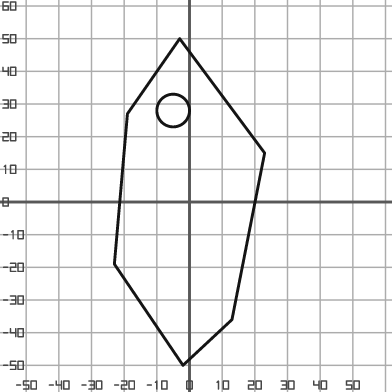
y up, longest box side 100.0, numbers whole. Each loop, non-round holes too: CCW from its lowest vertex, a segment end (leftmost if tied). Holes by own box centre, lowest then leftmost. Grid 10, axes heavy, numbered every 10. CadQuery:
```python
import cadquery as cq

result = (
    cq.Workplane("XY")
    .moveTo(-2.0, -50.0)
    .lineTo(13.0, -36.0)
    .lineTo(23.0, 15.0)
    .lineTo(-3.0, 50.0)
    .lineTo(-19.0, 27.0)
    .lineTo(-23.0, -19.0)
    .close()
    .moveTo(-5.0, 28.0)
    .circle(5.0)
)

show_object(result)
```